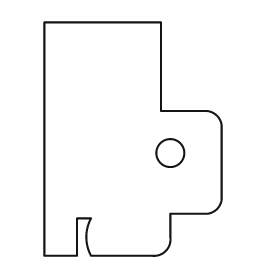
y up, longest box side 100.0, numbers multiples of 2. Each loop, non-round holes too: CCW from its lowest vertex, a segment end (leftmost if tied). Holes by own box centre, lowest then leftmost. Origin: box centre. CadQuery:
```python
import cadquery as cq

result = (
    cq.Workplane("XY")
    .moveTo(-38.0, -50.0)
    .lineTo(-24.0, -50.0)
    .lineTo(-24.0, -34.0)
    .lineTo(-18.0, -34.0)
    .threePointArc((-20.0, -42.0), (-18.0, -50.0))
    .lineTo(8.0, -50.0)
    .threePointArc((14.0, -48.0), (16.0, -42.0))
    .lineTo(16.0, -32.0)
    .lineTo(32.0, -32.0)
    .threePointArc((36.0, -30.0), (38.0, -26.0))
    .lineTo(38.0, 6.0)
    .threePointArc((36.0, 10.0), (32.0, 12.0))
    .lineTo(12.0, 12.0)
    .lineTo(12.0, 50.0)
    .lineTo(-38.0, 50.0)
    .close()
    .moveTo(16.0, -6.0)
    .circle(6.0)
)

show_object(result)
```